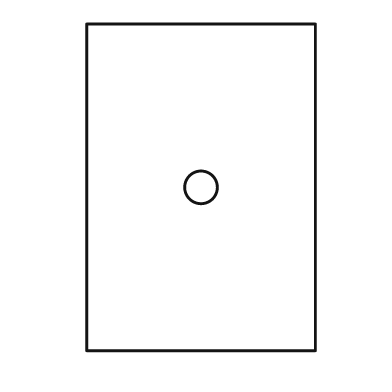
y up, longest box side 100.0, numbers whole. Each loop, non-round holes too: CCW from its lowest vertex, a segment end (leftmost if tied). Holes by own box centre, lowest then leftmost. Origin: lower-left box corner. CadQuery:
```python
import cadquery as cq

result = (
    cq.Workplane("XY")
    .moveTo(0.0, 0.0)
    .lineTo(70.0, 0.0)
    .lineTo(70.0, 100.0)
    .lineTo(0.0, 100.0)
    .close()
    .moveTo(35.0, 50.0)
    .circle(5.0)
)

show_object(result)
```